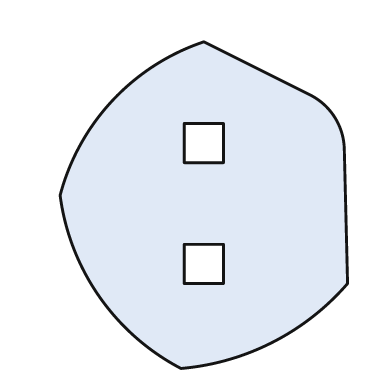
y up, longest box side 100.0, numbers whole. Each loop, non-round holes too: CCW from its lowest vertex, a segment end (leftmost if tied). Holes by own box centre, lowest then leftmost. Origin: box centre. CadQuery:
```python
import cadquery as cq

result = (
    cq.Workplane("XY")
    .moveTo(-7.0, -50.0)
    .threePointArc((21.0, -42.0), (44.0, -24.0))
    .lineTo(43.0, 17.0)
    .threePointArc((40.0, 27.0), (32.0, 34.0))
    .lineTo(0.0, 50.0)
    .threePointArc((-28.0, 32.0), (-44.0, 3.0))
    .threePointArc((-32.0, -28.0), (-7.0, -50.0))
    .close()
    .moveTo(-6.0, -24.0)
    .lineTo(6.0, -24.0)
    .lineTo(6.0, -12.0)
    .lineTo(-6.0, -12.0)
    .close()
    .moveTo(-6.0, 13.0)
    .lineTo(6.0, 13.0)
    .lineTo(6.0, 25.0)
    .lineTo(-6.0, 25.0)
    .close()
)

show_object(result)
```